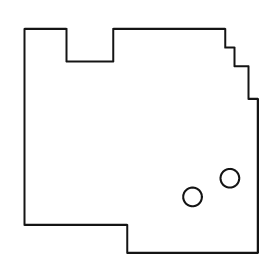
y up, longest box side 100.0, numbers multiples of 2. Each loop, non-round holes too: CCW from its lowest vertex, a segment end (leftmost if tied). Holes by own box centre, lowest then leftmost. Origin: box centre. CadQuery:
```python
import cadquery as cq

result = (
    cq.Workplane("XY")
    .moveTo(-6.0, -48.0)
    .lineTo(50.0, -48.0)
    .lineTo(50.0, 18.0)
    .lineTo(46.0, 18.0)
    .lineTo(46.0, 32.0)
    .lineTo(40.0, 32.0)
    .lineTo(40.0, 40.0)
    .lineTo(36.0, 40.0)
    .lineTo(36.0, 48.0)
    .lineTo(-12.0, 48.0)
    .lineTo(-12.0, 34.0)
    .lineTo(-32.0, 34.0)
    .lineTo(-32.0, 48.0)
    .lineTo(-50.0, 48.0)
    .lineTo(-50.0, -36.0)
    .lineTo(-6.0, -36.0)
    .close()
    .moveTo(22.0, -24.0)
    .circle(4.0)
    .moveTo(38.0, -16.0)
    .circle(4.0)
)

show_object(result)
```